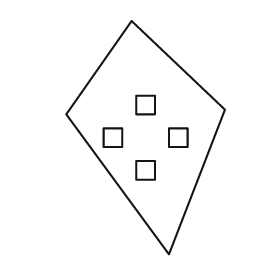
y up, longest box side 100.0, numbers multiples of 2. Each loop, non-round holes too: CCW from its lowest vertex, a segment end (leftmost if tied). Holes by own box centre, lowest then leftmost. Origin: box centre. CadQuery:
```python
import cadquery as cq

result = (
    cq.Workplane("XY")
    .moveTo(10.0, -50.0)
    .lineTo(34.0, 12.0)
    .lineTo(-6.0, 50.0)
    .lineTo(-34.0, 10.0)
    .close()
    .moveTo(-4.0, -18.0)
    .lineTo(4.0, -18.0)
    .lineTo(4.0, -10.0)
    .lineTo(-4.0, -10.0)
    .close()
    .moveTo(-18.0, -4.0)
    .lineTo(-10.0, -4.0)
    .lineTo(-10.0, 4.0)
    .lineTo(-18.0, 4.0)
    .close()
    .moveTo(10.0, -4.0)
    .lineTo(18.0, -4.0)
    .lineTo(18.0, 4.0)
    .lineTo(10.0, 4.0)
    .close()
    .moveTo(-4.0, 10.0)
    .lineTo(4.0, 10.0)
    .lineTo(4.0, 18.0)
    .lineTo(-4.0, 18.0)
    .close()
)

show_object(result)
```